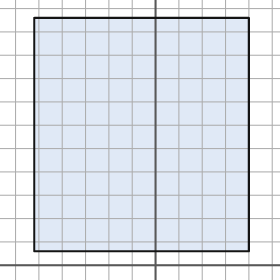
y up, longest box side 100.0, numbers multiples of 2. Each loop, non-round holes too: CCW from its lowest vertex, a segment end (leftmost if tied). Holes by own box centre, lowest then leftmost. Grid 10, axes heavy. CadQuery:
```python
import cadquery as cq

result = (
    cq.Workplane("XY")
    .moveTo(-52.0, 6.0)
    .lineTo(40.0, 6.0)
    .lineTo(40.0, 106.0)
    .lineTo(-52.0, 106.0)
    .close()
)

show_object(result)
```